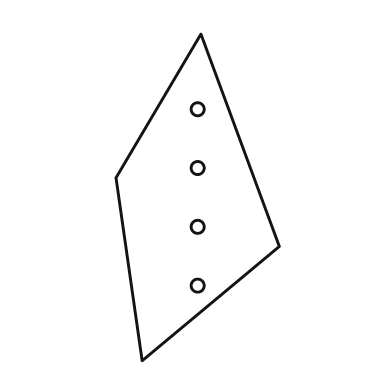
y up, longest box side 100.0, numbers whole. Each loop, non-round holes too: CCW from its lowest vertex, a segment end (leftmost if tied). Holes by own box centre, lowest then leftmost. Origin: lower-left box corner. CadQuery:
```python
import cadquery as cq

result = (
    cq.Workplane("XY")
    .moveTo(8.0, 0.0)
    .lineTo(50.0, 35.0)
    .lineTo(26.0, 100.0)
    .lineTo(0.0, 56.0)
    .close()
    .moveTo(25.0, 23.0)
    .circle(2.0)
    .moveTo(25.0, 41.0)
    .circle(2.0)
    .moveTo(25.0, 59.0)
    .circle(2.0)
    .moveTo(25.0, 77.0)
    .circle(2.0)
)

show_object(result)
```